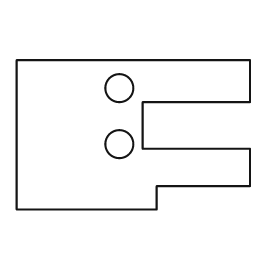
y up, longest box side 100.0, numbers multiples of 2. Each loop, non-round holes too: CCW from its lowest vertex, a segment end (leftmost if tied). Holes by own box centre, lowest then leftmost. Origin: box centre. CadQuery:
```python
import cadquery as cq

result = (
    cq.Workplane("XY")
    .moveTo(-50.0, -32.0)
    .lineTo(10.0, -32.0)
    .lineTo(10.0, -22.0)
    .lineTo(50.0, -22.0)
    .lineTo(50.0, -6.0)
    .lineTo(4.0, -6.0)
    .lineTo(4.0, 14.0)
    .lineTo(50.0, 14.0)
    .lineTo(50.0, 32.0)
    .lineTo(-50.0, 32.0)
    .close()
    .moveTo(-6.0, -4.0)
    .circle(6.0)
    .moveTo(-6.0, 20.0)
    .circle(6.0)
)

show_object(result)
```